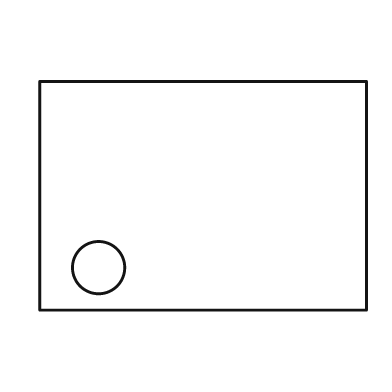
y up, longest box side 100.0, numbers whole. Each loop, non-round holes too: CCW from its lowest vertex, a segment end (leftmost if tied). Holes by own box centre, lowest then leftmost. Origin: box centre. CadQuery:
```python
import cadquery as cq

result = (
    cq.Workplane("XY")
    .moveTo(-50.0, -35.0)
    .lineTo(50.0, -35.0)
    .lineTo(50.0, 35.0)
    .lineTo(-50.0, 35.0)
    .close()
    .moveTo(-32.0, -22.0)
    .circle(8.0)
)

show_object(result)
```